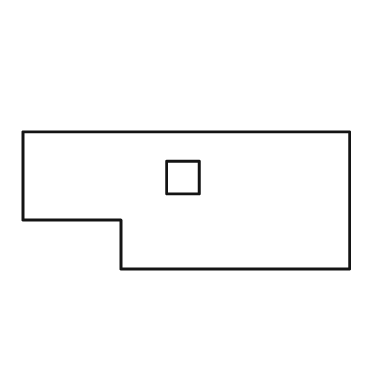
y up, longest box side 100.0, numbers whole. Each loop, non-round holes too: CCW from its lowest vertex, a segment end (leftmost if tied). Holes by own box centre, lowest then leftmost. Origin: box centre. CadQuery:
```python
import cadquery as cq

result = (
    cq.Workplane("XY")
    .moveTo(-20.0, -21.0)
    .lineTo(50.0, -21.0)
    .lineTo(50.0, 21.0)
    .lineTo(-50.0, 21.0)
    .lineTo(-50.0, -6.0)
    .lineTo(-20.0, -6.0)
    .close()
    .moveTo(-6.0, 2.0)
    .lineTo(4.0, 2.0)
    .lineTo(4.0, 12.0)
    .lineTo(-6.0, 12.0)
    .close()
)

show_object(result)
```